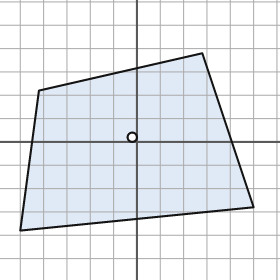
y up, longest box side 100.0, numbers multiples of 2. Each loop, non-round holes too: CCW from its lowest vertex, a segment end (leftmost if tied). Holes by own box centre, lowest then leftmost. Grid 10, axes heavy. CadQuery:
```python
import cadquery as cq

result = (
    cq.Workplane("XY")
    .moveTo(-50.0, -38.0)
    .lineTo(50.0, -28.0)
    .lineTo(28.0, 38.0)
    .lineTo(-42.0, 22.0)
    .close()
    .moveTo(-2.0, 2.0)
    .circle(2.0)
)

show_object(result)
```